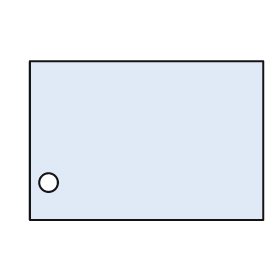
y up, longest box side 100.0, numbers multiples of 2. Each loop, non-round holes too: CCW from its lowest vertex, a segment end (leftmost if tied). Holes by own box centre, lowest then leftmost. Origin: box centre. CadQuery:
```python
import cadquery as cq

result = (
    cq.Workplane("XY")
    .moveTo(-50.0, -34.0)
    .lineTo(50.0, -34.0)
    .lineTo(50.0, 34.0)
    .lineTo(-50.0, 34.0)
    .close()
    .moveTo(-42.0, -18.0)
    .circle(4.0)
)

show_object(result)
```